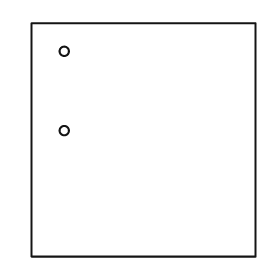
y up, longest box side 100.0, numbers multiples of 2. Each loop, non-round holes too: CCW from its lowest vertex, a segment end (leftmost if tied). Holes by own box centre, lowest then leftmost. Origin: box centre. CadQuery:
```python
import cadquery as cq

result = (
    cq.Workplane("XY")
    .moveTo(-48.0, -50.0)
    .lineTo(48.0, -50.0)
    .lineTo(48.0, 50.0)
    .lineTo(-48.0, 50.0)
    .close()
    .moveTo(-34.0, 4.0)
    .circle(2.0)
    .moveTo(-34.0, 38.0)
    .circle(2.0)
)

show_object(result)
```